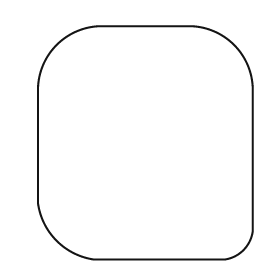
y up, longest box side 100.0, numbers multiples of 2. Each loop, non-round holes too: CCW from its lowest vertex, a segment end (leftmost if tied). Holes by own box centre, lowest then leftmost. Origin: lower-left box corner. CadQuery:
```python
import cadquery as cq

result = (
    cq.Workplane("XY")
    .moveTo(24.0, 0.0)
    .lineTo(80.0, 0.0)
    .threePointArc((88.0, 4.0), (92.0, 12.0))
    .lineTo(92.0, 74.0)
    .threePointArc((84.0, 92.0), (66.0, 100.0))
    .lineTo(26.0, 100.0)
    .threePointArc((8.0, 92.0), (0.0, 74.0))
    .lineTo(0.0, 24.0)
    .threePointArc((8.0, 8.0), (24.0, 0.0))
    .close()
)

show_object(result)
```